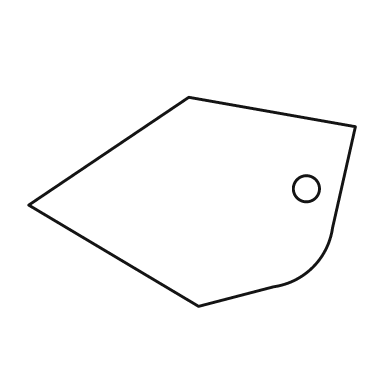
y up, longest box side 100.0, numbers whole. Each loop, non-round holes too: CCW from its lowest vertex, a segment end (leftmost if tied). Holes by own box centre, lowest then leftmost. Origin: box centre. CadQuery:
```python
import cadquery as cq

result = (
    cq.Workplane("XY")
    .moveTo(2.0, -32.0)
    .lineTo(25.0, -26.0)
    .threePointArc((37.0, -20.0), (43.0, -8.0))
    .lineTo(50.0, 23.0)
    .lineTo(-1.0, 32.0)
    .lineTo(-50.0, -1.0)
    .close()
    .moveTo(35.0, 4.0)
    .circle(4.0)
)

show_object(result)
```